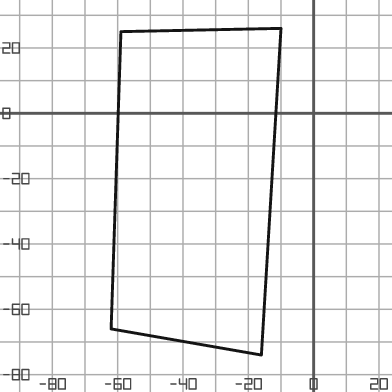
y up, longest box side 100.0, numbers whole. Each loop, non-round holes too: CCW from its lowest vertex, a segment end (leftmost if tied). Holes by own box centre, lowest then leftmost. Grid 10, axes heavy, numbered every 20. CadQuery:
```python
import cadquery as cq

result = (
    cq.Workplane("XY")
    .moveTo(-16.0, -74.0)
    .lineTo(-10.0, 26.0)
    .lineTo(-59.0, 25.0)
    .lineTo(-62.0, -66.0)
    .close()
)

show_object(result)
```